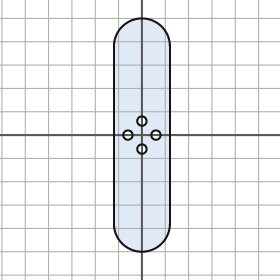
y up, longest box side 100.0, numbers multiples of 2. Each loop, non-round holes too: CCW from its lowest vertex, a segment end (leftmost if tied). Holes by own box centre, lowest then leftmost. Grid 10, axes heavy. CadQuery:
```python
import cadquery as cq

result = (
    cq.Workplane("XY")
    .moveTo(-12.0, -38.0)
    .threePointArc((0.0, -50.0), (12.0, -38.0))
    .lineTo(12.0, 38.0)
    .threePointArc((0.0, 50.0), (-12.0, 38.0))
    .close()
    .moveTo(0.0, -6.0)
    .circle(2.0)
    .moveTo(-6.0, 0.0)
    .circle(2.0)
    .moveTo(6.0, 0.0)
    .circle(2.0)
    .moveTo(0.0, 6.0)
    .circle(2.0)
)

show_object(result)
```